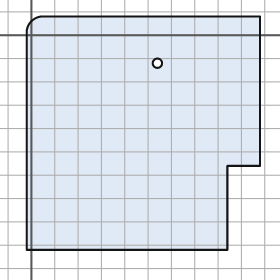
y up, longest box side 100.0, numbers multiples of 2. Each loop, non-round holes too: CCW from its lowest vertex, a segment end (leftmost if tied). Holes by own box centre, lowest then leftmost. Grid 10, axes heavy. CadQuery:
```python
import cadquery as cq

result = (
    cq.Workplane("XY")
    .moveTo(-2.0, -92.0)
    .lineTo(84.0, -92.0)
    .lineTo(84.0, -56.0)
    .lineTo(98.0, -56.0)
    .lineTo(98.0, 8.0)
    .lineTo(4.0, 8.0)
    .threePointArc((0.0, 6.0), (-2.0, 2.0))
    .close()
    .moveTo(54.0, -12.0)
    .circle(2.0)
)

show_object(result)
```